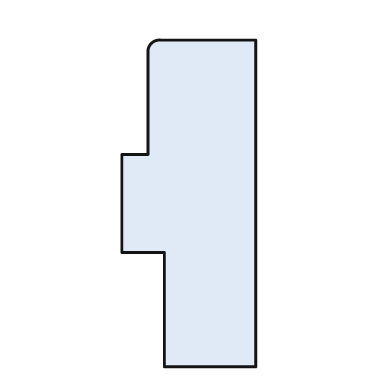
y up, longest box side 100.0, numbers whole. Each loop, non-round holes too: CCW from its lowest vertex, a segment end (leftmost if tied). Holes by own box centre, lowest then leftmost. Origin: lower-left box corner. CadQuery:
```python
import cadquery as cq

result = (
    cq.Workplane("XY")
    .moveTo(13.0, 0.0)
    .lineTo(41.0, 0.0)
    .lineTo(41.0, 100.0)
    .lineTo(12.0, 100.0)
    .threePointArc((9.0, 99.0), (8.0, 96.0))
    .lineTo(8.0, 65.0)
    .lineTo(0.0, 65.0)
    .lineTo(0.0, 35.0)
    .lineTo(13.0, 35.0)
    .close()
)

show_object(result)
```